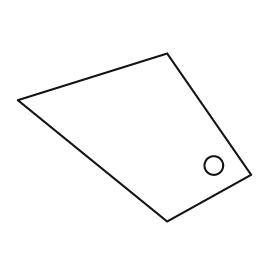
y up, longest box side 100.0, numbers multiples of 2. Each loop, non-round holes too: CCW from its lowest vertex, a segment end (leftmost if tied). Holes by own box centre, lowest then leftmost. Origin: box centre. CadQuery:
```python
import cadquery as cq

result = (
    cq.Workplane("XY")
    .moveTo(14.0, -36.0)
    .lineTo(50.0, -16.0)
    .lineTo(14.0, 36.0)
    .lineTo(-50.0, 16.0)
    .close()
    .moveTo(34.0, -12.0)
    .circle(4.0)
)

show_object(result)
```